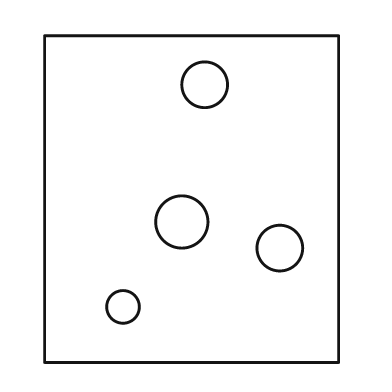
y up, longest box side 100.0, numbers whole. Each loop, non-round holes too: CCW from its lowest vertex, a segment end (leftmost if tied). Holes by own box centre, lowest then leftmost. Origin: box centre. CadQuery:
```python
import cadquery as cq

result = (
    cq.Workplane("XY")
    .moveTo(-45.0, -50.0)
    .lineTo(45.0, -50.0)
    .lineTo(45.0, 50.0)
    .lineTo(-45.0, 50.0)
    .close()
    .moveTo(-21.0, -33.0)
    .circle(5.0)
    .moveTo(27.0, -15.0)
    .circle(7.0)
    .moveTo(-3.0, -7.0)
    .circle(8.0)
    .moveTo(4.0, 35.0)
    .circle(7.0)
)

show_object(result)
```